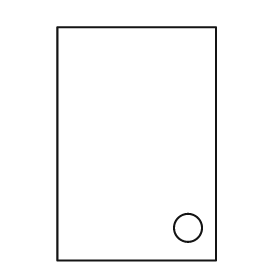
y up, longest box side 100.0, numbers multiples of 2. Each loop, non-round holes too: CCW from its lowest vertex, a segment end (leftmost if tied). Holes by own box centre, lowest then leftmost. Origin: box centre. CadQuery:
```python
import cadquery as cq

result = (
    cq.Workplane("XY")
    .moveTo(-34.0, -50.0)
    .lineTo(34.0, -50.0)
    .lineTo(34.0, 50.0)
    .lineTo(-34.0, 50.0)
    .close()
    .moveTo(22.0, -36.0)
    .circle(6.0)
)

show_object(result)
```